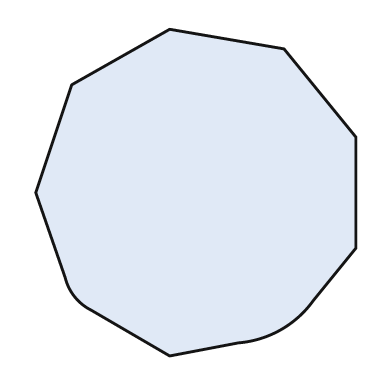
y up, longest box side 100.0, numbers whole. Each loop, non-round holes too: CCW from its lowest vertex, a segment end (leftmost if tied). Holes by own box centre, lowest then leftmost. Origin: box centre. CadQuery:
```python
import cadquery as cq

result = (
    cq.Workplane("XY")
    .moveTo(-8.0, -50.0)
    .lineTo(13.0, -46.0)
    .threePointArc((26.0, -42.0), (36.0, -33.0))
    .lineTo(49.0, -17.0)
    .lineTo(49.0, 17.0)
    .lineTo(27.0, 44.0)
    .lineTo(-8.0, 50.0)
    .lineTo(-38.0, 33.0)
    .lineTo(-49.0, 0.0)
    .lineTo(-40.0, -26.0)
    .threePointArc((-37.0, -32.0), (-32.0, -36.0))
    .close()
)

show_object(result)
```